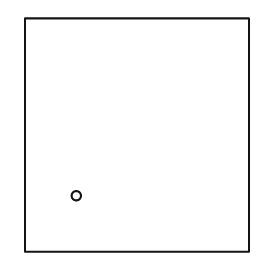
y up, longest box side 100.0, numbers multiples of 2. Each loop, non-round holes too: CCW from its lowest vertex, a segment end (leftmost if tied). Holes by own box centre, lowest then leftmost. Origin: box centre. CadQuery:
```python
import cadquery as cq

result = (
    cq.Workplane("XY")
    .moveTo(-48.0, -50.0)
    .lineTo(48.0, -50.0)
    .lineTo(48.0, 50.0)
    .lineTo(-48.0, 50.0)
    .close()
    .moveTo(-26.0, -26.0)
    .circle(2.0)
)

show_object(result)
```